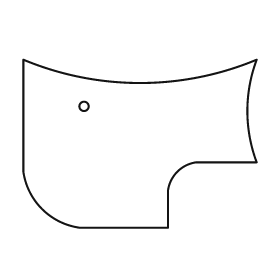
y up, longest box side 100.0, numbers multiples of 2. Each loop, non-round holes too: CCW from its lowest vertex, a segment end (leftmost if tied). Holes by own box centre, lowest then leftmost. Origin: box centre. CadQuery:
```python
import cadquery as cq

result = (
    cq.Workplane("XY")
    .moveTo(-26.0, -36.0)
    .lineTo(12.0, -36.0)
    .lineTo(12.0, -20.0)
    .threePointArc((16.0, -12.0), (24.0, -8.0))
    .lineTo(50.0, -8.0)
    .threePointArc((46.0, 14.0), (50.0, 36.0))
    .threePointArc((0.0, 26.0), (-50.0, 36.0))
    .lineTo(-50.0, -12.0)
    .threePointArc((-42.0, -28.0), (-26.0, -36.0))
    .close()
    .moveTo(-24.0, 16.0)
    .circle(2.0)
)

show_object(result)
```